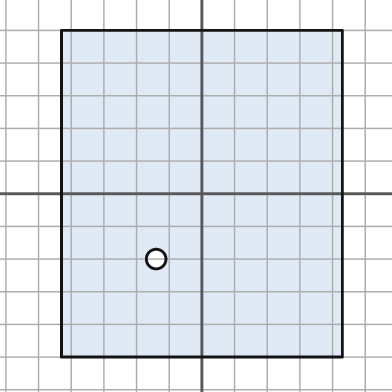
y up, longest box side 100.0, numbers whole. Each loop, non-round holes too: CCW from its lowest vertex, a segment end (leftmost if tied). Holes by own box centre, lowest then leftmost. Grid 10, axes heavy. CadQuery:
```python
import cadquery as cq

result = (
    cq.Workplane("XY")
    .moveTo(-43.0, -50.0)
    .lineTo(43.0, -50.0)
    .lineTo(43.0, 50.0)
    .lineTo(-43.0, 50.0)
    .close()
    .moveTo(-14.0, -20.0)
    .circle(3.0)
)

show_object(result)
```